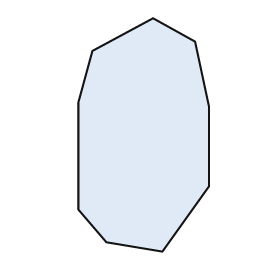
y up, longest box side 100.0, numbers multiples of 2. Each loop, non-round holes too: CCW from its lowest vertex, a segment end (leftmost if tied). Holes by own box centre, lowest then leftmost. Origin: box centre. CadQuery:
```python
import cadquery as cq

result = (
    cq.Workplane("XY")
    .moveTo(8.0, -50.0)
    .lineTo(28.0, -22.0)
    .lineTo(28.0, 12.0)
    .lineTo(22.0, 40.0)
    .lineTo(4.0, 50.0)
    .lineTo(-22.0, 36.0)
    .lineTo(-28.0, 14.0)
    .lineTo(-28.0, -32.0)
    .lineTo(-16.0, -46.0)
    .close()
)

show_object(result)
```